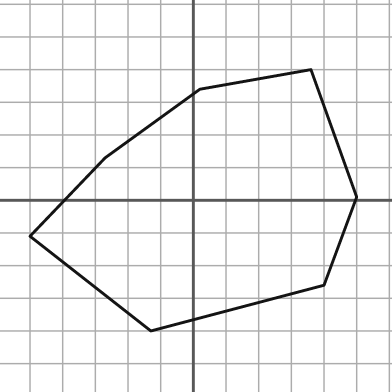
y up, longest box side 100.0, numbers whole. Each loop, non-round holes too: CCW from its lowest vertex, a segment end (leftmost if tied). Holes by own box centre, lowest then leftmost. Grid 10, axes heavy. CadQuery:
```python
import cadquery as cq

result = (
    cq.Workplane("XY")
    .moveTo(-13.0, -40.0)
    .lineTo(40.0, -26.0)
    .lineTo(50.0, 1.0)
    .lineTo(36.0, 40.0)
    .lineTo(2.0, 34.0)
    .lineTo(-27.0, 13.0)
    .lineTo(-50.0, -11.0)
    .close()
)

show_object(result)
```